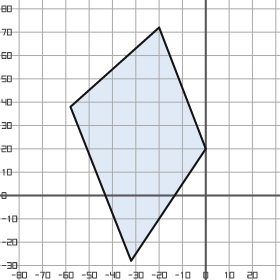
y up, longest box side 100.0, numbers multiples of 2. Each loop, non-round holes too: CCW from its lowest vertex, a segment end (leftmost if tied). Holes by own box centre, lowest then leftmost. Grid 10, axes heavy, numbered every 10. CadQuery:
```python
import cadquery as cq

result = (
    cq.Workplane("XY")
    .moveTo(-32.0, -28.0)
    .lineTo(0.0, 20.0)
    .lineTo(-20.0, 72.0)
    .lineTo(-58.0, 38.0)
    .close()
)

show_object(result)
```